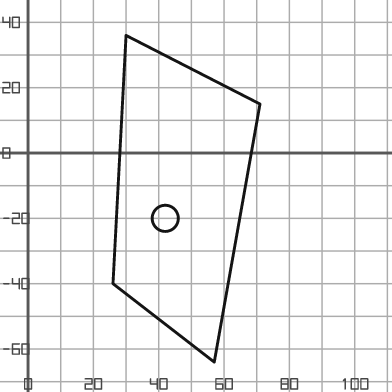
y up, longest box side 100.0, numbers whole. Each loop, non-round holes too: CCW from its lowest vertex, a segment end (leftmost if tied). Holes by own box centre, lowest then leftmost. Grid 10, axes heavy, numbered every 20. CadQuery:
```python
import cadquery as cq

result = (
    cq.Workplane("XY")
    .moveTo(57.0, -64.0)
    .lineTo(71.0, 15.0)
    .lineTo(30.0, 36.0)
    .lineTo(26.0, -40.0)
    .close()
    .moveTo(42.0, -20.0)
    .circle(4.0)
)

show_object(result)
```